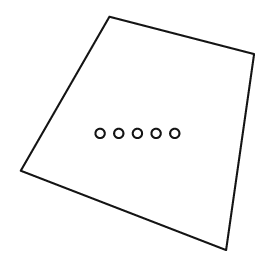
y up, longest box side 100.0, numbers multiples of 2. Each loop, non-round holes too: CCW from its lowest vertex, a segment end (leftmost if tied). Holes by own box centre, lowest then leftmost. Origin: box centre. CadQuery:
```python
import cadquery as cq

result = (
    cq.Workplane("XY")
    .moveTo(38.0, -50.0)
    .lineTo(50.0, 34.0)
    .lineTo(-12.0, 50.0)
    .lineTo(-50.0, -16.0)
    .close()
    .moveTo(-16.0, 0.0)
    .circle(2.0)
    .moveTo(-8.0, 0.0)
    .circle(2.0)
    .moveTo(0.0, 0.0)
    .circle(2.0)
    .moveTo(8.0, 0.0)
    .circle(2.0)
    .moveTo(16.0, 0.0)
    .circle(2.0)
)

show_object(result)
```